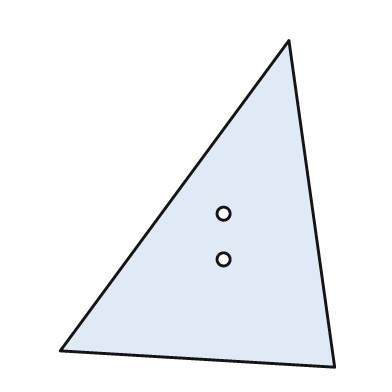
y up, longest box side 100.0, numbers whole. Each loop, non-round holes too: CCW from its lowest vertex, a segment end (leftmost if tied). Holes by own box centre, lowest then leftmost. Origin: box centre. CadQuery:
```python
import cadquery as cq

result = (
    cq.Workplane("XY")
    .moveTo(42.0, -50.0)
    .lineTo(28.0, 50.0)
    .lineTo(-42.0, -45.0)
    .close()
    .moveTo(8.0, -17.0)
    .circle(2.0)
    .moveTo(8.0, -3.0)
    .circle(2.0)
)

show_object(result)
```